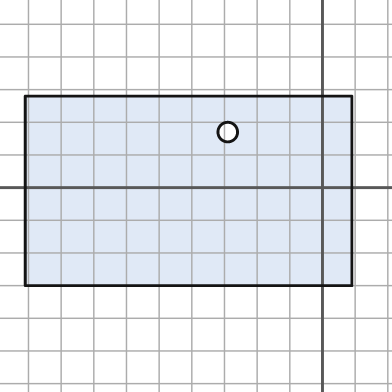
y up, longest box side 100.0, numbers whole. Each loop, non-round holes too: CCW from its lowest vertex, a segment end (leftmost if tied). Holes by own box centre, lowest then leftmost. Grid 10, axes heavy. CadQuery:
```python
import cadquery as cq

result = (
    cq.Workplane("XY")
    .moveTo(-91.0, -30.0)
    .lineTo(9.0, -30.0)
    .lineTo(9.0, 28.0)
    .lineTo(-91.0, 28.0)
    .close()
    .moveTo(-29.0, 17.0)
    .circle(3.0)
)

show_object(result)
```